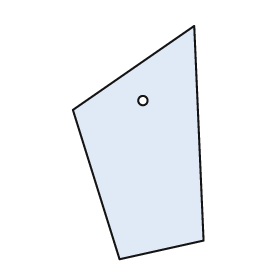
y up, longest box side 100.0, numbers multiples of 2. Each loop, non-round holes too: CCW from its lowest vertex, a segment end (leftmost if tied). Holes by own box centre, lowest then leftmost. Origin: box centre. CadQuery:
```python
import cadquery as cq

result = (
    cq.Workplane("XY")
    .moveTo(-8.0, -50.0)
    .lineTo(28.0, -42.0)
    .lineTo(24.0, 50.0)
    .lineTo(-28.0, 14.0)
    .close()
    .moveTo(2.0, 18.0)
    .circle(2.0)
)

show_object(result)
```